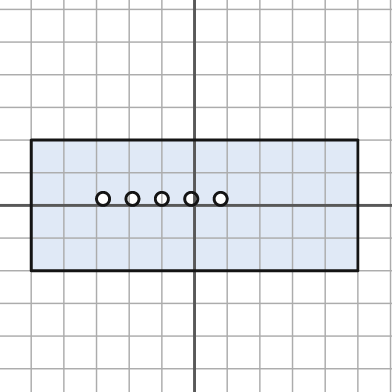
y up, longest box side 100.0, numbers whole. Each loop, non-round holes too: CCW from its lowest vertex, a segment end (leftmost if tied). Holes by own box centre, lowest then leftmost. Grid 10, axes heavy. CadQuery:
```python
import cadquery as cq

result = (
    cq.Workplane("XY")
    .moveTo(-50.0, -20.0)
    .lineTo(50.0, -20.0)
    .lineTo(50.0, 20.0)
    .lineTo(-50.0, 20.0)
    .close()
    .moveTo(-28.0, 2.0)
    .circle(2.0)
    .moveTo(-19.0, 2.0)
    .circle(2.0)
    .moveTo(-10.0, 2.0)
    .circle(2.0)
    .moveTo(-1.0, 2.0)
    .circle(2.0)
    .moveTo(8.0, 2.0)
    .circle(2.0)
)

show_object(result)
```